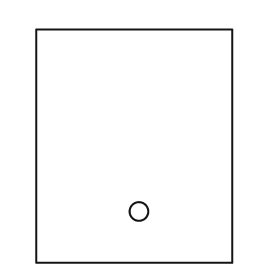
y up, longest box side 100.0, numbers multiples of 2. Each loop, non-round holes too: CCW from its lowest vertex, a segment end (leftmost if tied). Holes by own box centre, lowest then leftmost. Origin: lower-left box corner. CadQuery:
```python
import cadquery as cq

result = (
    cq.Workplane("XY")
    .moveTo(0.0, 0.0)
    .lineTo(84.0, 0.0)
    .lineTo(84.0, 100.0)
    .lineTo(0.0, 100.0)
    .close()
    .moveTo(44.0, 22.0)
    .circle(4.0)
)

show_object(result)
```